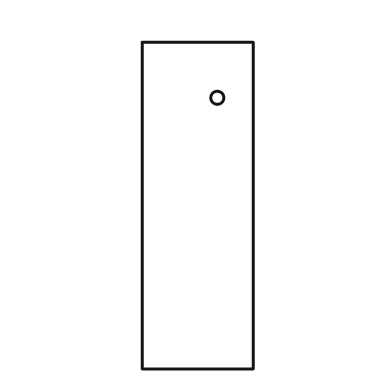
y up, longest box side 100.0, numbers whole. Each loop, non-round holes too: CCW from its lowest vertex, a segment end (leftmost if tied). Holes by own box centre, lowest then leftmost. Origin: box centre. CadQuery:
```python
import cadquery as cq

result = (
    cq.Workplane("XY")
    .moveTo(-17.0, -50.0)
    .lineTo(17.0, -50.0)
    .lineTo(17.0, 50.0)
    .lineTo(-17.0, 50.0)
    .close()
    .moveTo(6.0, 33.0)
    .circle(2.0)
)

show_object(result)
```